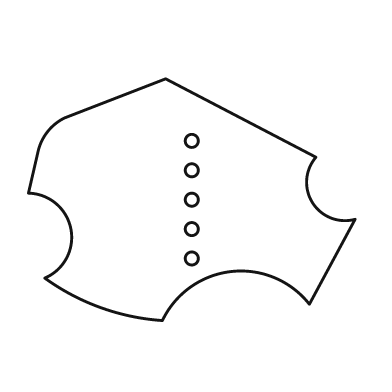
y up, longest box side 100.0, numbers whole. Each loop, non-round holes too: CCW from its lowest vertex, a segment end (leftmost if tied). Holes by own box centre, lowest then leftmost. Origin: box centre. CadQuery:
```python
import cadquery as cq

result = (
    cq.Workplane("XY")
    .moveTo(-9.0, -37.0)
    .threePointArc((12.0, -22.0), (36.0, -32.0))
    .lineTo(50.0, -6.0)
    .threePointArc((37.0, -1.0), (38.0, 13.0))
    .lineTo(-8.0, 37.0)
    .lineTo(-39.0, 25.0)
    .threePointArc((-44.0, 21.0), (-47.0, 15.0))
    .lineTo(-50.0, 2.0)
    .threePointArc((-37.0, -9.0), (-45.0, -24.0))
    .threePointArc((-28.0, -33.0), (-9.0, -37.0))
    .close()
    .moveTo(0.0, -18.0)
    .circle(2.0)
    .moveTo(0.0, -9.0)
    .circle(2.0)
    .moveTo(0.0, 0.0)
    .circle(2.0)
    .moveTo(0.0, 9.0)
    .circle(2.0)
    .moveTo(0.0, 18.0)
    .circle(2.0)
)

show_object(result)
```